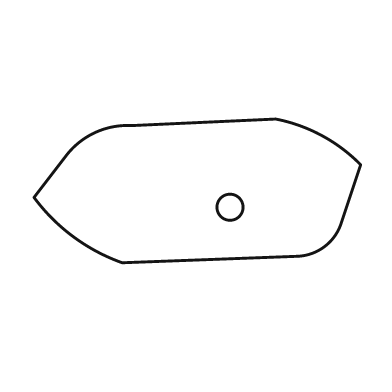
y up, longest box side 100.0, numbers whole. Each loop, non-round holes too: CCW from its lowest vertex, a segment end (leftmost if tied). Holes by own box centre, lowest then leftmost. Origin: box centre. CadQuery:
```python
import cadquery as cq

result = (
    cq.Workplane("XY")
    .moveTo(-23.0, -22.0)
    .lineTo(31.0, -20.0)
    .threePointArc((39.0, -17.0), (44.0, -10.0))
    .lineTo(50.0, 8.0)
    .threePointArc((38.0, 17.0), (24.0, 22.0))
    .lineTo(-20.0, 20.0)
    .threePointArc((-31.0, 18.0), (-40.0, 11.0))
    .lineTo(-50.0, -2.0)
    .threePointArc((-38.0, -14.0), (-23.0, -22.0))
    .close()
    .moveTo(10.0, -5.0)
    .circle(4.0)
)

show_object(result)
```